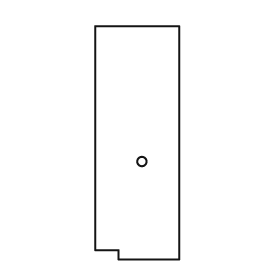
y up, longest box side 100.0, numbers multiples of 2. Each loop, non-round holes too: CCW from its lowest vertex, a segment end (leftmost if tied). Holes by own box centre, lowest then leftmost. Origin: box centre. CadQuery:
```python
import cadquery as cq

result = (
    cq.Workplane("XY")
    .moveTo(-8.0, -50.0)
    .lineTo(18.0, -50.0)
    .lineTo(18.0, 50.0)
    .lineTo(-18.0, 50.0)
    .lineTo(-18.0, -46.0)
    .lineTo(-8.0, -46.0)
    .close()
    .moveTo(2.0, -8.0)
    .circle(2.0)
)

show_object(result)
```